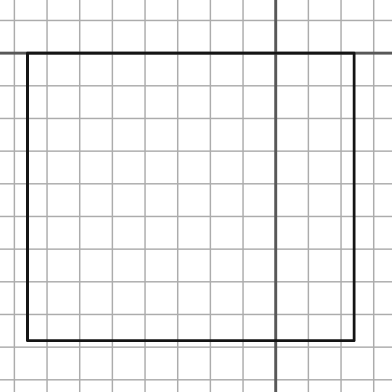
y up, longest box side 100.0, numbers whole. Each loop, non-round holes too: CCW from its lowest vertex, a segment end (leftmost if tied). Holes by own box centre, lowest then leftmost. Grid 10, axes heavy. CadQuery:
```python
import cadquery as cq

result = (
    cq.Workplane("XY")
    .moveTo(-76.0, -88.0)
    .lineTo(24.0, -88.0)
    .lineTo(24.0, 0.0)
    .lineTo(-76.0, 0.0)
    .close()
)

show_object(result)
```